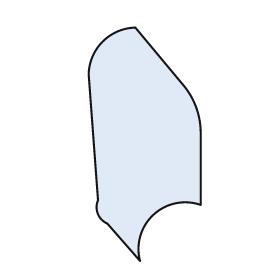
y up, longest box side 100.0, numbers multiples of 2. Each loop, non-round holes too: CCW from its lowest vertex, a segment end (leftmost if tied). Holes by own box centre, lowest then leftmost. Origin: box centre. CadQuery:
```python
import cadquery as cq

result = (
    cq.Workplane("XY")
    .moveTo(-2.0, -50.0)
    .threePointArc((4.0, -30.0), (24.0, -26.0))
    .lineTo(24.0, 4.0)
    .threePointArc((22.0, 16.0), (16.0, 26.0))
    .lineTo(-4.0, 50.0)
    .threePointArc((-18.0, 44.0), (-24.0, 30.0))
    .lineTo(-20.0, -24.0)
    .threePointArc((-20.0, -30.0), (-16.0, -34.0))
    .close()
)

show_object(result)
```